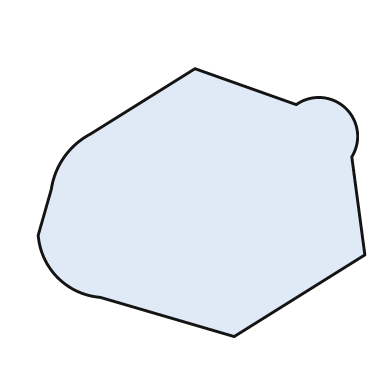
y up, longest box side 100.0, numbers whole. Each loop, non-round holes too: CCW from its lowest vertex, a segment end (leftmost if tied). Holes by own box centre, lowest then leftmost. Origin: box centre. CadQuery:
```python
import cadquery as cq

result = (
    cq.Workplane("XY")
    .moveTo(10.0, -41.0)
    .lineTo(50.0, -16.0)
    .lineTo(46.0, 14.0)
    .threePointArc((44.0, 29.0), (29.0, 30.0))
    .lineTo(-2.0, 41.0)
    .lineTo(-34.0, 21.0)
    .threePointArc((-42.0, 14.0), (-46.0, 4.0))
    .lineTo(-50.0, -10.0)
    .threePointArc((-44.0, -23.0), (-31.0, -29.0))
    .close()
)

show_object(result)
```